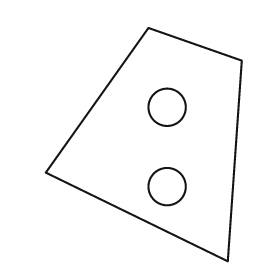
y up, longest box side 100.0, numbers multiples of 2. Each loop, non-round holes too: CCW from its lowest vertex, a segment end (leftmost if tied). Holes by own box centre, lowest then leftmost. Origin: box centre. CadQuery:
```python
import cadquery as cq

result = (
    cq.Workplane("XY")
    .moveTo(36.0, -50.0)
    .lineTo(42.0, 36.0)
    .lineTo(2.0, 50.0)
    .lineTo(-42.0, -12.0)
    .close()
    .moveTo(10.0, -18.0)
    .circle(8.0)
    .moveTo(10.0, 16.0)
    .circle(8.0)
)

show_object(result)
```